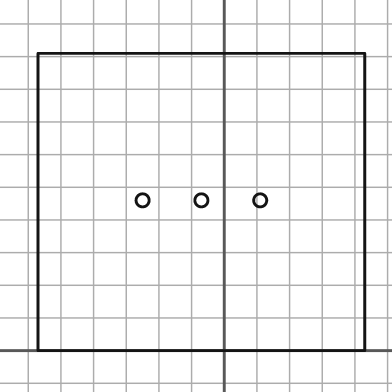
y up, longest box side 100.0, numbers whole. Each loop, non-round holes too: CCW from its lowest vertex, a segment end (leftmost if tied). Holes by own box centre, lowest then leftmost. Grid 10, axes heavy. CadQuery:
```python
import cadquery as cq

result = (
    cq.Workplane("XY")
    .moveTo(-57.0, 0.0)
    .lineTo(43.0, 0.0)
    .lineTo(43.0, 91.0)
    .lineTo(-57.0, 91.0)
    .close()
    .moveTo(-25.0, 46.0)
    .circle(2.0)
    .moveTo(-7.0, 46.0)
    .circle(2.0)
    .moveTo(11.0, 46.0)
    .circle(2.0)
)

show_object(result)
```